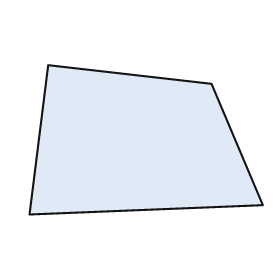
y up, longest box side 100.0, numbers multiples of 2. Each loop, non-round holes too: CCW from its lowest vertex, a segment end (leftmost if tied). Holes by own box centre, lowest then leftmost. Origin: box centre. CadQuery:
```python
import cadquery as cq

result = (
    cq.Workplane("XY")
    .moveTo(-50.0, -32.0)
    .lineTo(50.0, -28.0)
    .lineTo(28.0, 24.0)
    .lineTo(-42.0, 32.0)
    .close()
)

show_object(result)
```